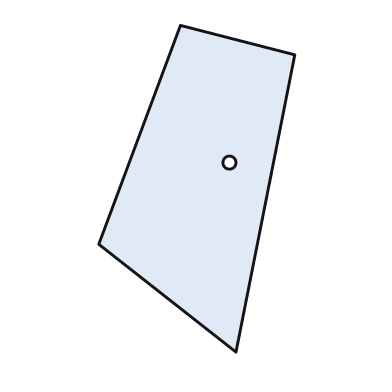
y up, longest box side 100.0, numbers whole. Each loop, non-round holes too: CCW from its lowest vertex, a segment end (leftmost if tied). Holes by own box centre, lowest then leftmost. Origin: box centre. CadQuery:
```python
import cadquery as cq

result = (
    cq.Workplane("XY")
    .moveTo(12.0, -50.0)
    .lineTo(30.0, 41.0)
    .lineTo(-5.0, 50.0)
    .lineTo(-30.0, -17.0)
    .close()
    .moveTo(10.0, 8.0)
    .circle(2.0)
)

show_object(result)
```